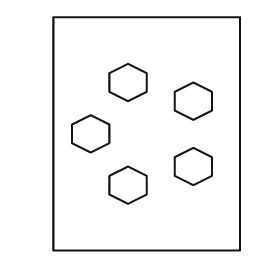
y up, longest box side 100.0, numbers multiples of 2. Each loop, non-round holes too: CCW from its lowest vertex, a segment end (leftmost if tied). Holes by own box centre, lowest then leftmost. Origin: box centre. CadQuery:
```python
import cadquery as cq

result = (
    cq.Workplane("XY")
    .moveTo(-40.0, -50.0)
    .lineTo(40.0, -50.0)
    .lineTo(40.0, 50.0)
    .lineTo(-40.0, 50.0)
    .close()
    .moveTo(-8.0, -30.0)
    .lineTo(0.0, -26.0)
    .lineTo(0.0, -18.0)
    .lineTo(-8.0, -14.0)
    .lineTo(-16.0, -18.0)
    .lineTo(-16.0, -26.0)
    .close()
    .moveTo(20.0, -22.0)
    .lineTo(28.0, -18.0)
    .lineTo(28.0, -10.0)
    .lineTo(20.0, -6.0)
    .lineTo(12.0, -10.0)
    .lineTo(12.0, -18.0)
    .close()
    .moveTo(-24.0, -8.0)
    .lineTo(-16.0, -4.0)
    .lineTo(-16.0, 4.0)
    .lineTo(-24.0, 8.0)
    .lineTo(-32.0, 4.0)
    .lineTo(-32.0, -4.0)
    .close()
    .moveTo(20.0, 6.0)
    .lineTo(28.0, 10.0)
    .lineTo(28.0, 18.0)
    .lineTo(20.0, 22.0)
    .lineTo(12.0, 18.0)
    .lineTo(12.0, 10.0)
    .close()
    .moveTo(-8.0, 14.0)
    .lineTo(0.0, 18.0)
    .lineTo(0.0, 26.0)
    .lineTo(-8.0, 30.0)
    .lineTo(-16.0, 26.0)
    .lineTo(-16.0, 18.0)
    .close()
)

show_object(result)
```